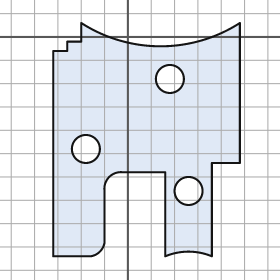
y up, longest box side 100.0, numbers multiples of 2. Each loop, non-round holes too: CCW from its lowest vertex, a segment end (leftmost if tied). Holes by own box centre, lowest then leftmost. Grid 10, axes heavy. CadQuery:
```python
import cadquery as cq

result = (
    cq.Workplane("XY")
    .moveTo(-32.0, -94.0)
    .lineTo(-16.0, -94.0)
    .threePointArc((-12.0, -92.0), (-10.0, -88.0))
    .lineTo(-10.0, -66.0)
    .threePointArc((-8.0, -60.0), (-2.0, -58.0))
    .lineTo(16.0, -58.0)
    .lineTo(16.0, -94.0)
    .threePointArc((26.0, -92.0), (36.0, -94.0))
    .lineTo(36.0, -54.0)
    .lineTo(48.0, -54.0)
    .lineTo(48.0, 6.0)
    .threePointArc((14.0, -4.0), (-20.0, 6.0))
    .lineTo(-20.0, -2.0)
    .lineTo(-26.0, -2.0)
    .lineTo(-26.0, -6.0)
    .lineTo(-32.0, -6.0)
    .close()
    .moveTo(26.0, -66.0)
    .circle(6.0)
    .moveTo(-18.0, -48.0)
    .circle(6.0)
    .moveTo(18.0, -18.0)
    .circle(6.0)
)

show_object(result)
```